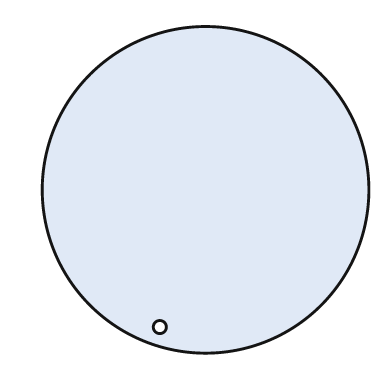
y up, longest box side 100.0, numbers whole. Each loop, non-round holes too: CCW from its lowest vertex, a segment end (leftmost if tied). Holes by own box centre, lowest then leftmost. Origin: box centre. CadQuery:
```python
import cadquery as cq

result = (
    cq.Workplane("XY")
    .moveTo(0.0, 0.0)
    .circle(50.0)
    .moveTo(-14.0, -42.0)
    .circle(2.0)
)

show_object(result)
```